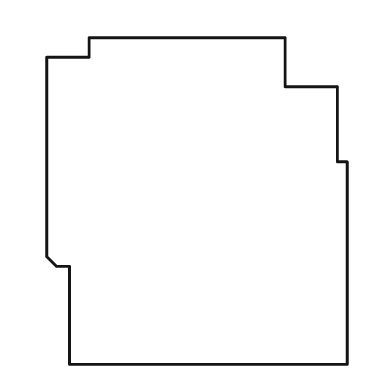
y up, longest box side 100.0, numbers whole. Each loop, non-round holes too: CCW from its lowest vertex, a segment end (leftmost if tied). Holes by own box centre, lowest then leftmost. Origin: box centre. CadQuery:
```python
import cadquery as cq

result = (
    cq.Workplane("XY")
    .moveTo(-39.0, -50.0)
    .lineTo(46.0, -50.0)
    .lineTo(46.0, 12.0)
    .lineTo(43.0, 12.0)
    .lineTo(43.0, 35.0)
    .lineTo(27.0, 35.0)
    .lineTo(27.0, 50.0)
    .lineTo(-33.0, 50.0)
    .lineTo(-33.0, 44.0)
    .lineTo(-46.0, 44.0)
    .lineTo(-46.0, -17.0)
    .lineTo(-43.0, -20.0)
    .lineTo(-39.0, -20.0)
    .close()
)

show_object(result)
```